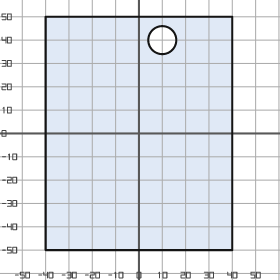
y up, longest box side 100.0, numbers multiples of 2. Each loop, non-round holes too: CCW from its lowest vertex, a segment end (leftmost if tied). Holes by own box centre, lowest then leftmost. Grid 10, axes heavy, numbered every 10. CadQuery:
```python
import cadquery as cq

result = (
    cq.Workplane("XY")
    .moveTo(-40.0, -50.0)
    .lineTo(40.0, -50.0)
    .lineTo(40.0, 50.0)
    .lineTo(-40.0, 50.0)
    .close()
    .moveTo(10.0, 40.0)
    .circle(6.0)
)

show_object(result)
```